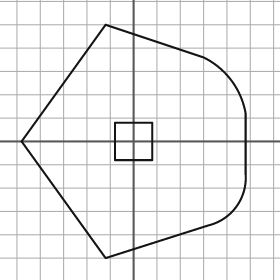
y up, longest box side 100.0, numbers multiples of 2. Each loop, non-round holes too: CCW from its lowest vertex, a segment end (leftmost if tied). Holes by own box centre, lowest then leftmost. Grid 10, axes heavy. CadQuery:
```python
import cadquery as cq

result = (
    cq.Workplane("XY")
    .moveTo(-12.0, -50.0)
    .lineTo(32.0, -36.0)
    .threePointArc((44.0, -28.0), (48.0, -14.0))
    .lineTo(48.0, 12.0)
    .threePointArc((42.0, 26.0), (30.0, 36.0))
    .lineTo(-12.0, 50.0)
    .lineTo(-48.0, 0.0)
    .close()
    .moveTo(-8.0, -8.0)
    .lineTo(8.0, -8.0)
    .lineTo(8.0, 8.0)
    .lineTo(-8.0, 8.0)
    .close()
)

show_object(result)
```